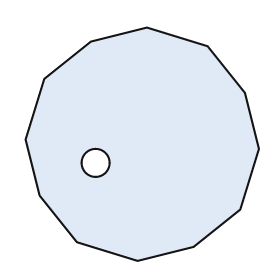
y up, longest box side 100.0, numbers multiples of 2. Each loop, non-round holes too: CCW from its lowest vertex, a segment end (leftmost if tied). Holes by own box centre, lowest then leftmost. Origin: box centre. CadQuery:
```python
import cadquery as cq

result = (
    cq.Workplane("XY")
    .moveTo(-2.0, -50.0)
    .lineTo(22.0, -44.0)
    .lineTo(42.0, -28.0)
    .lineTo(50.0, -2.0)
    .lineTo(44.0, 22.0)
    .lineTo(28.0, 42.0)
    .lineTo(2.0, 50.0)
    .lineTo(-22.0, 44.0)
    .lineTo(-42.0, 28.0)
    .lineTo(-50.0, 2.0)
    .lineTo(-44.0, -22.0)
    .lineTo(-28.0, -42.0)
    .close()
    .moveTo(-20.0, -8.0)
    .circle(6.0)
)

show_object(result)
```